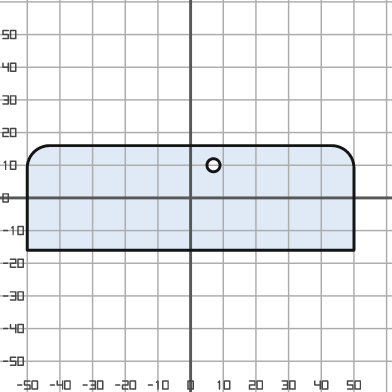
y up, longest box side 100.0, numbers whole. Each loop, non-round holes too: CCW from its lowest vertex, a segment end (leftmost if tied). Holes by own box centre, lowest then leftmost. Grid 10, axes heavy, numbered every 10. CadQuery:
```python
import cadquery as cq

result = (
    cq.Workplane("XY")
    .moveTo(-50.0, -16.0)
    .lineTo(50.0, -16.0)
    .lineTo(50.0, 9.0)
    .threePointArc((48.0, 14.0), (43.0, 16.0))
    .lineTo(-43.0, 16.0)
    .threePointArc((-48.0, 14.0), (-50.0, 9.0))
    .close()
    .moveTo(7.0, 10.0)
    .circle(2.0)
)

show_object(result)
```